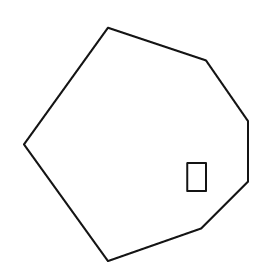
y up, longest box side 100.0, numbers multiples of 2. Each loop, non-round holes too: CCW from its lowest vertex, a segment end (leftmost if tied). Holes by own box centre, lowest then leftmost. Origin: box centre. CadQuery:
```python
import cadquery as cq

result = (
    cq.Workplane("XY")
    .moveTo(-12.0, -50.0)
    .lineTo(28.0, -36.0)
    .lineTo(48.0, -16.0)
    .lineTo(48.0, 10.0)
    .lineTo(30.0, 36.0)
    .lineTo(-12.0, 50.0)
    .lineTo(-48.0, 0.0)
    .close()
    .moveTo(22.0, -20.0)
    .lineTo(30.0, -20.0)
    .lineTo(30.0, -8.0)
    .lineTo(22.0, -8.0)
    .close()
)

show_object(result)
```